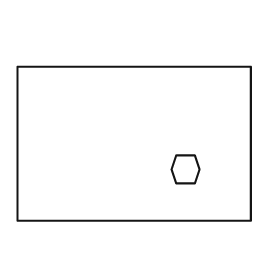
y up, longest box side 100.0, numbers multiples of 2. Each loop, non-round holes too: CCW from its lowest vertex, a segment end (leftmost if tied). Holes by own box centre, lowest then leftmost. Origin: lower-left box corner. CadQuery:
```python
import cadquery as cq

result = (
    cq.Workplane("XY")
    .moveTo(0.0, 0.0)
    .lineTo(100.0, 0.0)
    .lineTo(100.0, 66.0)
    .lineTo(0.0, 66.0)
    .close()
    .moveTo(68.0, 16.0)
    .lineTo(76.0, 16.0)
    .lineTo(78.0, 22.0)
    .lineTo(76.0, 28.0)
    .lineTo(68.0, 28.0)
    .lineTo(66.0, 22.0)
    .close()
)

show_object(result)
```